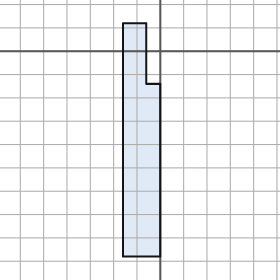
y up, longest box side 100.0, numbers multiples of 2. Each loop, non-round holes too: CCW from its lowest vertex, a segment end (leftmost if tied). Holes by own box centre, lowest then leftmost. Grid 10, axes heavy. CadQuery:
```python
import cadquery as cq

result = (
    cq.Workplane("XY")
    .moveTo(-16.0, -88.0)
    .lineTo(0.0, -88.0)
    .lineTo(0.0, -14.0)
    .lineTo(-6.0, -14.0)
    .lineTo(-6.0, 12.0)
    .lineTo(-16.0, 12.0)
    .close()
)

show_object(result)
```